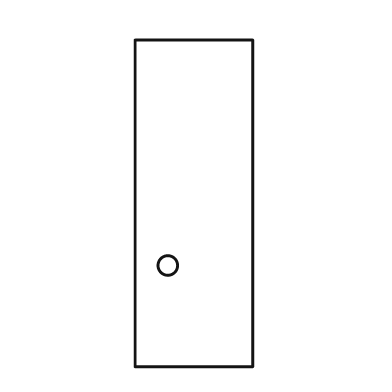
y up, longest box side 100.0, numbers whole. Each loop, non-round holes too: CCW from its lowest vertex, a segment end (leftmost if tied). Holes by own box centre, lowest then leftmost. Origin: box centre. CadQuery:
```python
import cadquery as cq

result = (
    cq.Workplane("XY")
    .moveTo(-18.0, -50.0)
    .lineTo(18.0, -50.0)
    .lineTo(18.0, 50.0)
    .lineTo(-18.0, 50.0)
    .close()
    .moveTo(-8.0, -19.0)
    .circle(3.0)
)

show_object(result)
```